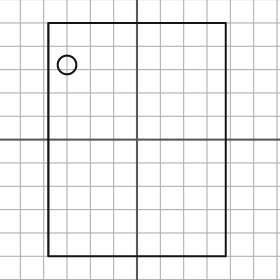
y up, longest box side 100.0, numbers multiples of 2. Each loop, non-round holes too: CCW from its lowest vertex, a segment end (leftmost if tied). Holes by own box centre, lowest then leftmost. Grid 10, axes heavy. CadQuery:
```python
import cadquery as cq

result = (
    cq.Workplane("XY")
    .moveTo(-38.0, -50.0)
    .lineTo(38.0, -50.0)
    .lineTo(38.0, 50.0)
    .lineTo(-38.0, 50.0)
    .close()
    .moveTo(-30.0, 32.0)
    .circle(4.0)
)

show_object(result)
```